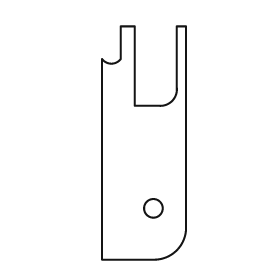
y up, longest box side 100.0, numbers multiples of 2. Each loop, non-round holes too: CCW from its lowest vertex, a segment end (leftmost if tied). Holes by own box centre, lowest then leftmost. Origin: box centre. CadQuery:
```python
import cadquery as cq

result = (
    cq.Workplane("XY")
    .moveTo(-18.0, -50.0)
    .lineTo(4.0, -50.0)
    .threePointArc((14.0, -46.0), (18.0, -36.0))
    .lineTo(18.0, 50.0)
    .lineTo(14.0, 50.0)
    .lineTo(14.0, 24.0)
    .threePointArc((12.0, 18.0), (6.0, 16.0))
    .lineTo(-4.0, 16.0)
    .lineTo(-4.0, 50.0)
    .lineTo(-10.0, 50.0)
    .lineTo(-10.0, 36.0)
    .threePointArc((-14.0, 34.0), (-18.0, 36.0))
    .close()
    .moveTo(4.0, -28.0)
    .circle(4.0)
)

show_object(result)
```